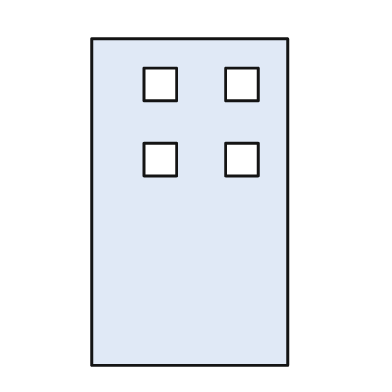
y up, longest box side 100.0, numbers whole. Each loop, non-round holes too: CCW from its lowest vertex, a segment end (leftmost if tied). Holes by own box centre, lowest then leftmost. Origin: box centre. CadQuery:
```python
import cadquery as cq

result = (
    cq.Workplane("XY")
    .moveTo(-30.0, -50.0)
    .lineTo(30.0, -50.0)
    .lineTo(30.0, 50.0)
    .lineTo(-30.0, 50.0)
    .close()
    .moveTo(-14.0, 8.0)
    .lineTo(-4.0, 8.0)
    .lineTo(-4.0, 18.0)
    .lineTo(-14.0, 18.0)
    .close()
    .moveTo(11.0, 8.0)
    .lineTo(21.0, 8.0)
    .lineTo(21.0, 18.0)
    .lineTo(11.0, 18.0)
    .close()
    .moveTo(-14.0, 31.0)
    .lineTo(-4.0, 31.0)
    .lineTo(-4.0, 41.0)
    .lineTo(-14.0, 41.0)
    .close()
    .moveTo(11.0, 31.0)
    .lineTo(21.0, 31.0)
    .lineTo(21.0, 41.0)
    .lineTo(11.0, 41.0)
    .close()
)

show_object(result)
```